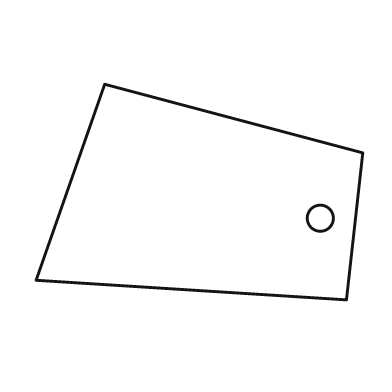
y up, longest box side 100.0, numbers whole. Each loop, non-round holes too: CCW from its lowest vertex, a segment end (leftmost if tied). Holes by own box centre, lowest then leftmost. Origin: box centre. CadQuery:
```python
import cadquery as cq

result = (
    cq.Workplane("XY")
    .moveTo(45.0, -33.0)
    .lineTo(50.0, 12.0)
    .lineTo(-29.0, 33.0)
    .lineTo(-50.0, -27.0)
    .close()
    .moveTo(37.0, -8.0)
    .circle(4.0)
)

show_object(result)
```